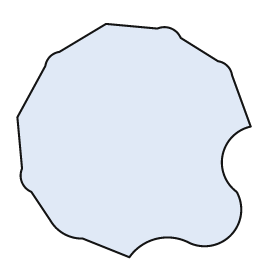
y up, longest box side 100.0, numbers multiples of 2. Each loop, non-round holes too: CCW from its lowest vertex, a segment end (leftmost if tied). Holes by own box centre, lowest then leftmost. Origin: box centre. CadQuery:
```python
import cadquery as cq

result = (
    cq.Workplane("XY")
    .moveTo(-2.0, -50.0)
    .threePointArc((10.0, -42.0), (24.0, -44.0))
    .threePointArc((42.0, -40.0), (44.0, -22.0))
    .threePointArc((38.0, -6.0), (50.0, 6.0))
    .lineTo(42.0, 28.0)
    .threePointArc((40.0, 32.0), (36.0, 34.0))
    .lineTo(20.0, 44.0)
    .threePointArc((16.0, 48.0), (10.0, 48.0))
    .lineTo(-12.0, 50.0)
    .lineTo(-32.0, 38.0)
    .threePointArc((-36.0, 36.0), (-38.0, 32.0))
    .lineTo(-50.0, 10.0)
    .lineTo(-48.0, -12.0)
    .threePointArc((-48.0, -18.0), (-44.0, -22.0))
    .lineTo(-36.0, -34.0)
    .threePointArc((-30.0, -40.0), (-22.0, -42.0))
    .close()
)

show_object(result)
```